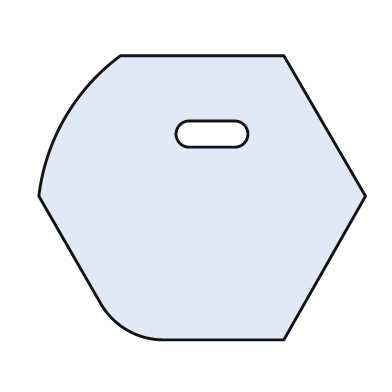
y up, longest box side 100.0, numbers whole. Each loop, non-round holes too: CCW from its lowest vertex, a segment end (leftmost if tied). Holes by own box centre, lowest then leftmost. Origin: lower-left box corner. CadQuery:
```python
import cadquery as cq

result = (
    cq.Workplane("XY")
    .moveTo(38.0, 0.0)
    .lineTo(75.0, 0.0)
    .lineTo(100.0, 44.0)
    .lineTo(75.0, 87.0)
    .lineTo(25.0, 87.0)
    .threePointArc((8.0, 68.0), (0.0, 44.0))
    .lineTo(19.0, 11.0)
    .threePointArc((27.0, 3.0), (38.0, 0.0))
    .close()
    .moveTo(46.0, 59.0)
    .lineTo(60.0, 59.0)
    .threePointArc((64.0, 63.0), (60.0, 67.0))
    .lineTo(46.0, 67.0)
    .threePointArc((42.0, 63.0), (46.0, 59.0))
    .close()
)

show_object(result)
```